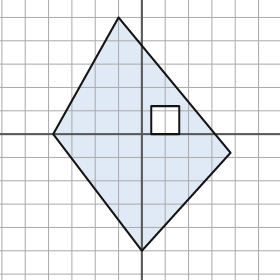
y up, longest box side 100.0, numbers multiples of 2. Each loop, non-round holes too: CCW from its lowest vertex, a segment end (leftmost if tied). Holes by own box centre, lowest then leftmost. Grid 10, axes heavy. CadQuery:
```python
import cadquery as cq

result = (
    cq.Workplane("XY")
    .moveTo(0.0, -50.0)
    .lineTo(38.0, -8.0)
    .lineTo(-10.0, 50.0)
    .lineTo(-38.0, 0.0)
    .close()
    .moveTo(4.0, 0.0)
    .lineTo(16.0, 0.0)
    .lineTo(16.0, 12.0)
    .lineTo(4.0, 12.0)
    .close()
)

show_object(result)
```